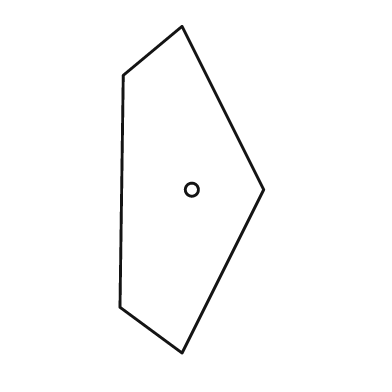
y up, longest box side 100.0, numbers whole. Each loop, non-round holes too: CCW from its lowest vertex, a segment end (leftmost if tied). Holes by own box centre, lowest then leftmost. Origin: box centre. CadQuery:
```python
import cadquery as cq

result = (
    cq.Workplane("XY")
    .moveTo(-3.0, -50.0)
    .lineTo(22.0, 0.0)
    .lineTo(-3.0, 50.0)
    .lineTo(-21.0, 35.0)
    .lineTo(-22.0, -36.0)
    .close()
    .moveTo(0.0, 0.0)
    .circle(2.0)
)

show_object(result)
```